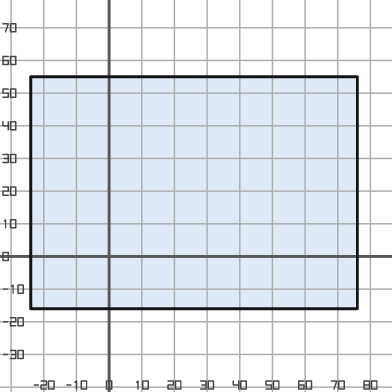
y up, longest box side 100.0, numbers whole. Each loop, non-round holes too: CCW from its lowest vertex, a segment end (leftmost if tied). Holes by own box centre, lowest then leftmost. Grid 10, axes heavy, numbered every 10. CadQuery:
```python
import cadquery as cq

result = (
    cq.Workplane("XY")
    .moveTo(-24.0, -16.0)
    .lineTo(76.0, -16.0)
    .lineTo(76.0, 55.0)
    .lineTo(-24.0, 55.0)
    .close()
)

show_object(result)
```